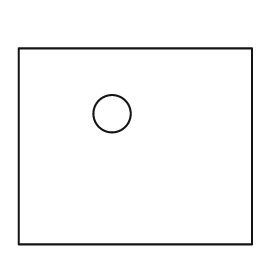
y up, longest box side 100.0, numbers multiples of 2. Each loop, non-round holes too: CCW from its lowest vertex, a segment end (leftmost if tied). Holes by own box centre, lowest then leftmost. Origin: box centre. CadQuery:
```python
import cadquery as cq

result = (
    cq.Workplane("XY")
    .moveTo(-50.0, -42.0)
    .lineTo(50.0, -42.0)
    .lineTo(50.0, 42.0)
    .lineTo(-50.0, 42.0)
    .close()
    .moveTo(-10.0, 14.0)
    .circle(8.0)
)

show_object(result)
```